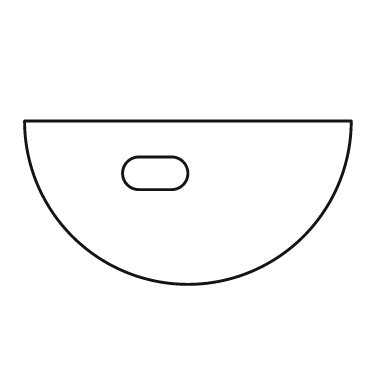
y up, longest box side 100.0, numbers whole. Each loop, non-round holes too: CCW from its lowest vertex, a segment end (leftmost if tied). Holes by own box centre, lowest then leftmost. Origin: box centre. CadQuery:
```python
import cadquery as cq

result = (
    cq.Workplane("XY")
    .moveTo(-50.0, 25.0)
    .threePointArc((0.0, -25.0), (50.0, 25.0))
    .close()
    .moveTo(-15.0, 4.0)
    .lineTo(-5.0, 4.0)
    .threePointArc((0.0, 9.0), (-5.0, 14.0))
    .lineTo(-15.0, 14.0)
    .threePointArc((-20.0, 9.0), (-15.0, 4.0))
    .close()
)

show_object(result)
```